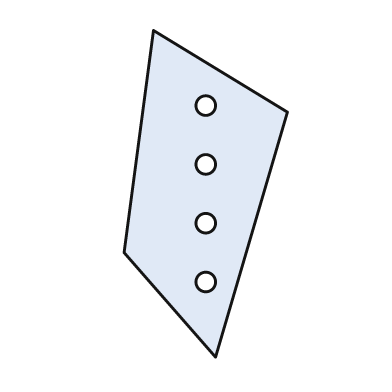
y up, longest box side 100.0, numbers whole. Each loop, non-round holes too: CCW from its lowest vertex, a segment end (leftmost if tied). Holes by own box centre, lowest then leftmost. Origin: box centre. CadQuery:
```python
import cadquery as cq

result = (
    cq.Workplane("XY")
    .moveTo(3.0, -50.0)
    .lineTo(25.0, 25.0)
    .lineTo(-16.0, 50.0)
    .lineTo(-25.0, -18.0)
    .close()
    .moveTo(0.0, -27.0)
    .circle(3.0)
    .moveTo(0.0, -9.0)
    .circle(3.0)
    .moveTo(0.0, 9.0)
    .circle(3.0)
    .moveTo(0.0, 27.0)
    .circle(3.0)
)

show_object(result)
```